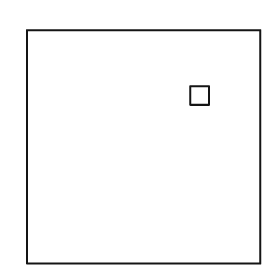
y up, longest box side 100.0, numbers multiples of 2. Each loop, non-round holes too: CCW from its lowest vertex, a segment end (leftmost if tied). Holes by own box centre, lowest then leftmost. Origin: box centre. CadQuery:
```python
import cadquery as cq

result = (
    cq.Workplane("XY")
    .moveTo(-50.0, -50.0)
    .lineTo(50.0, -50.0)
    .lineTo(50.0, 50.0)
    .lineTo(-50.0, 50.0)
    .close()
    .moveTo(20.0, 18.0)
    .lineTo(28.0, 18.0)
    .lineTo(28.0, 26.0)
    .lineTo(20.0, 26.0)
    .close()
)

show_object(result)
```